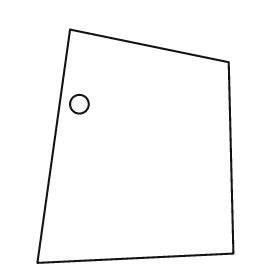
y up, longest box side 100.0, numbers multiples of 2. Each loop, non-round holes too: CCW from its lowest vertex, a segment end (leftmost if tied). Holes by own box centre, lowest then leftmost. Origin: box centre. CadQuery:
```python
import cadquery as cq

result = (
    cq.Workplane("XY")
    .moveTo(-42.0, -50.0)
    .lineTo(42.0, -46.0)
    .lineTo(40.0, 36.0)
    .lineTo(-28.0, 50.0)
    .close()
    .moveTo(-24.0, 18.0)
    .circle(4.0)
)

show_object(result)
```